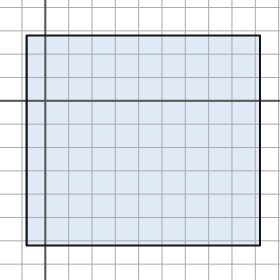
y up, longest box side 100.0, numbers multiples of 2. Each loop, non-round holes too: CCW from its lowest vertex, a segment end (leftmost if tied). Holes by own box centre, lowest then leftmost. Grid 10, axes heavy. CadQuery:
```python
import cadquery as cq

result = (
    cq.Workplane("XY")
    .moveTo(-8.0, -62.0)
    .lineTo(92.0, -62.0)
    .lineTo(92.0, 28.0)
    .lineTo(-8.0, 28.0)
    .close()
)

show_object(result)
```